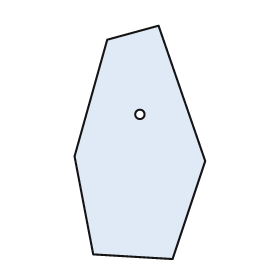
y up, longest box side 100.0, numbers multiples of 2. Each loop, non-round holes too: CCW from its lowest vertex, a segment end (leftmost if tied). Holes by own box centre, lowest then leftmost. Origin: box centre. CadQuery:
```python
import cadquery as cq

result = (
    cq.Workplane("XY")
    .moveTo(14.0, -50.0)
    .lineTo(28.0, -8.0)
    .lineTo(8.0, 50.0)
    .lineTo(-14.0, 44.0)
    .lineTo(-28.0, -6.0)
    .lineTo(-20.0, -48.0)
    .close()
    .moveTo(0.0, 12.0)
    .circle(2.0)
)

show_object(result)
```